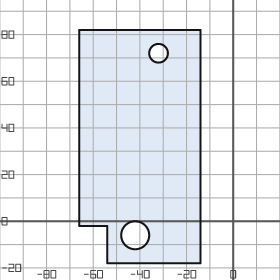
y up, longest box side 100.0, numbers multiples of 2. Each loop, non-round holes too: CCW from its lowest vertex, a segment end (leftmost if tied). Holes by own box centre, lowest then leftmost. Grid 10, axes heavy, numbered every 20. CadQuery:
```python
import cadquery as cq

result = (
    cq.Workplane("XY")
    .moveTo(-54.0, -18.0)
    .lineTo(-14.0, -18.0)
    .lineTo(-14.0, 82.0)
    .lineTo(-66.0, 82.0)
    .lineTo(-66.0, -2.0)
    .lineTo(-54.0, -2.0)
    .close()
    .moveTo(-42.0, -6.0)
    .circle(6.0)
    .moveTo(-32.0, 72.0)
    .circle(4.0)
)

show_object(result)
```